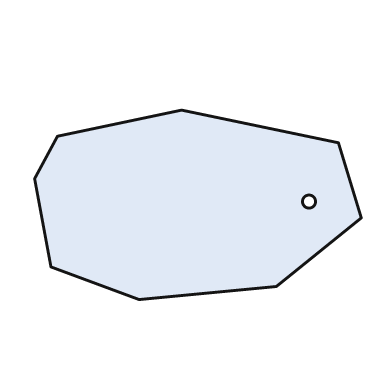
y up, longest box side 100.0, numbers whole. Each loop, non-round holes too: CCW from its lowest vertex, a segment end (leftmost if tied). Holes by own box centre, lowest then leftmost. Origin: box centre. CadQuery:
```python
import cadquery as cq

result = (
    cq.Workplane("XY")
    .moveTo(-18.0, -29.0)
    .lineTo(24.0, -25.0)
    .lineTo(50.0, -4.0)
    .lineTo(43.0, 19.0)
    .lineTo(-5.0, 29.0)
    .lineTo(-43.0, 21.0)
    .lineTo(-50.0, 8.0)
    .lineTo(-45.0, -19.0)
    .close()
    .moveTo(34.0, 1.0)
    .circle(2.0)
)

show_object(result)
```